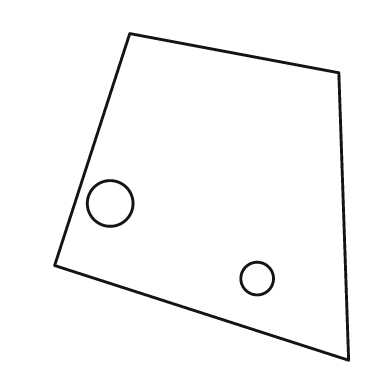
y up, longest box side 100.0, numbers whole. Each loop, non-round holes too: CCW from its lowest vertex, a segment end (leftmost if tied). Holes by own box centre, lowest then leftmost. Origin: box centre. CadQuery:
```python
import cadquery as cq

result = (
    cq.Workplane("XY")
    .moveTo(45.0, -50.0)
    .lineTo(42.0, 38.0)
    .lineTo(-22.0, 50.0)
    .lineTo(-45.0, -21.0)
    .close()
    .moveTo(17.0, -25.0)
    .circle(5.0)
    .moveTo(-28.0, -2.0)
    .circle(7.0)
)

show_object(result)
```